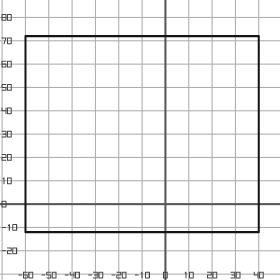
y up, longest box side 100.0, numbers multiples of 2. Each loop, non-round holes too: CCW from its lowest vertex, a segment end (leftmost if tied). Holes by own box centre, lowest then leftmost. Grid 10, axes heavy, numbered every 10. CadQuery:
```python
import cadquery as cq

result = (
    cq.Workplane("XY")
    .moveTo(-60.0, -12.0)
    .lineTo(40.0, -12.0)
    .lineTo(40.0, 72.0)
    .lineTo(-60.0, 72.0)
    .close()
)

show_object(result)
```